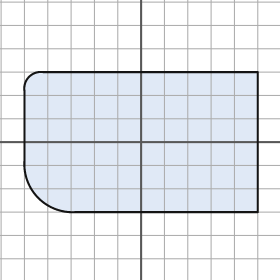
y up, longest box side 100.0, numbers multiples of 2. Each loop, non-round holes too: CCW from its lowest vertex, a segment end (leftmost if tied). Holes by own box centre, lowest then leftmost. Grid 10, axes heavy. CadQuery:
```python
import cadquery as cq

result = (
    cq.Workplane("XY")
    .moveTo(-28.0, -30.0)
    .lineTo(50.0, -30.0)
    .lineTo(50.0, 30.0)
    .lineTo(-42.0, 30.0)
    .threePointArc((-48.0, 28.0), (-50.0, 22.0))
    .lineTo(-50.0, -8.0)
    .threePointArc((-44.0, -24.0), (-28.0, -30.0))
    .close()
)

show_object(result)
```